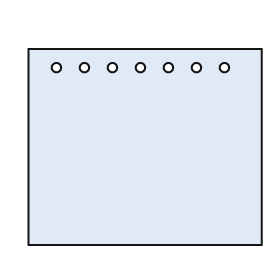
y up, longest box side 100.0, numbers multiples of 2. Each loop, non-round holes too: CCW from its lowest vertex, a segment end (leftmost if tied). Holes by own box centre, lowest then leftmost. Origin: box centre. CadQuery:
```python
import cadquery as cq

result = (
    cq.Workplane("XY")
    .moveTo(-50.0, -42.0)
    .lineTo(50.0, -42.0)
    .lineTo(50.0, 42.0)
    .lineTo(-50.0, 42.0)
    .close()
    .moveTo(-38.0, 34.0)
    .circle(2.0)
    .moveTo(-26.0, 34.0)
    .circle(2.0)
    .moveTo(-14.0, 34.0)
    .circle(2.0)
    .moveTo(-2.0, 34.0)
    .circle(2.0)
    .moveTo(10.0, 34.0)
    .circle(2.0)
    .moveTo(22.0, 34.0)
    .circle(2.0)
    .moveTo(34.0, 34.0)
    .circle(2.0)
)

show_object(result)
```